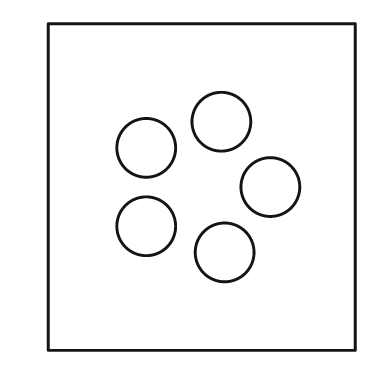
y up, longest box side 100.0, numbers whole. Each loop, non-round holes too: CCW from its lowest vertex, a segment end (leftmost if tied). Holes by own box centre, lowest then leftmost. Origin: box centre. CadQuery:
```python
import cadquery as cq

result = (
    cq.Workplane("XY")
    .moveTo(-47.0, -50.0)
    .lineTo(47.0, -50.0)
    .lineTo(47.0, 50.0)
    .lineTo(-47.0, 50.0)
    .close()
    .moveTo(7.0, -20.0)
    .circle(9.0)
    .moveTo(-17.0, -12.0)
    .circle(9.0)
    .moveTo(21.0, 0.0)
    .circle(9.0)
    .moveTo(-17.0, 12.0)
    .circle(9.0)
    .moveTo(6.0, 20.0)
    .circle(9.0)
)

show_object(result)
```